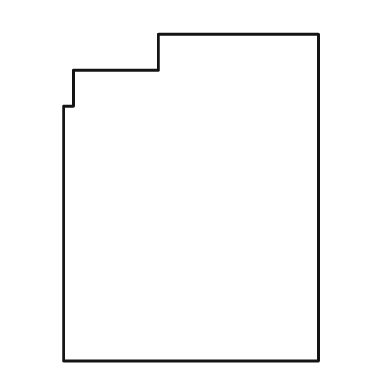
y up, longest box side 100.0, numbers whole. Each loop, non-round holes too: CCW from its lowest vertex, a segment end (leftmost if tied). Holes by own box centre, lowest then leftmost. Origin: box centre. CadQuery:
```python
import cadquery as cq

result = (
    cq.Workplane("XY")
    .moveTo(-39.0, -50.0)
    .lineTo(39.0, -50.0)
    .lineTo(39.0, 50.0)
    .lineTo(-10.0, 50.0)
    .lineTo(-10.0, 39.0)
    .lineTo(-36.0, 39.0)
    .lineTo(-36.0, 28.0)
    .lineTo(-39.0, 28.0)
    .close()
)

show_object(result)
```